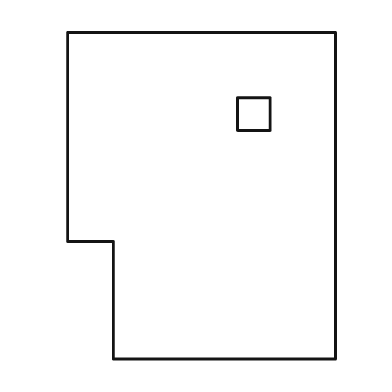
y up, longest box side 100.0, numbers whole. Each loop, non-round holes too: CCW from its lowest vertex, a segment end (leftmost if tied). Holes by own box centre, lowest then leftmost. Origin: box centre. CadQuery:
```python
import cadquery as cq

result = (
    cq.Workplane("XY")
    .moveTo(-27.0, -50.0)
    .lineTo(41.0, -50.0)
    .lineTo(41.0, 50.0)
    .lineTo(-41.0, 50.0)
    .lineTo(-41.0, -14.0)
    .lineTo(-27.0, -14.0)
    .close()
    .moveTo(11.0, 20.0)
    .lineTo(21.0, 20.0)
    .lineTo(21.0, 30.0)
    .lineTo(11.0, 30.0)
    .close()
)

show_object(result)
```